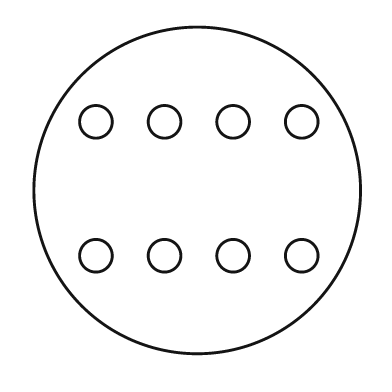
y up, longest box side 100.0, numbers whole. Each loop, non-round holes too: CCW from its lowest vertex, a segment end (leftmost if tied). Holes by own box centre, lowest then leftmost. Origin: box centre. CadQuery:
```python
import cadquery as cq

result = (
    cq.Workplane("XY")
    .moveTo(0.0, 0.0)
    .circle(50.0)
    .moveTo(-31.0, -20.0)
    .circle(5.0)
    .moveTo(-10.0, -20.0)
    .circle(5.0)
    .moveTo(11.0, -20.0)
    .circle(5.0)
    .moveTo(32.0, -20.0)
    .circle(5.0)
    .moveTo(-31.0, 21.0)
    .circle(5.0)
    .moveTo(-10.0, 21.0)
    .circle(5.0)
    .moveTo(11.0, 21.0)
    .circle(5.0)
    .moveTo(32.0, 21.0)
    .circle(5.0)
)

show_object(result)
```